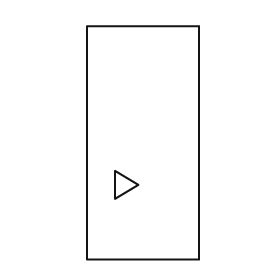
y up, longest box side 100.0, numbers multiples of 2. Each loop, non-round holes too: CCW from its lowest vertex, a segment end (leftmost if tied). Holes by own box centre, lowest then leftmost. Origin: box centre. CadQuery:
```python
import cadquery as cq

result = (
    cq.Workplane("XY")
    .moveTo(-24.0, -50.0)
    .lineTo(24.0, -50.0)
    .lineTo(24.0, 50.0)
    .lineTo(-24.0, 50.0)
    .close()
    .moveTo(-12.0, -24.0)
    .lineTo(-2.0, -18.0)
    .lineTo(-12.0, -12.0)
    .close()
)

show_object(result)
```